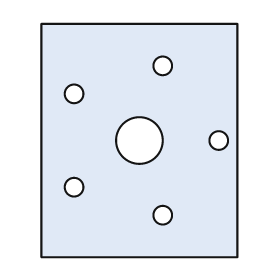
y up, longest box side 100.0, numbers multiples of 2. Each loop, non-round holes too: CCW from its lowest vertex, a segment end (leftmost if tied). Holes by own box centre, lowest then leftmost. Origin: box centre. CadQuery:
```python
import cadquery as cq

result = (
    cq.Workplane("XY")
    .moveTo(-42.0, -50.0)
    .lineTo(42.0, -50.0)
    .lineTo(42.0, 50.0)
    .lineTo(-42.0, 50.0)
    .close()
    .moveTo(10.0, -32.0)
    .circle(4.0)
    .moveTo(-28.0, -20.0)
    .circle(4.0)
    .moveTo(0.0, 0.0)
    .circle(10.0)
    .moveTo(34.0, 0.0)
    .circle(4.0)
    .moveTo(-28.0, 20.0)
    .circle(4.0)
    .moveTo(10.0, 32.0)
    .circle(4.0)
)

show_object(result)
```